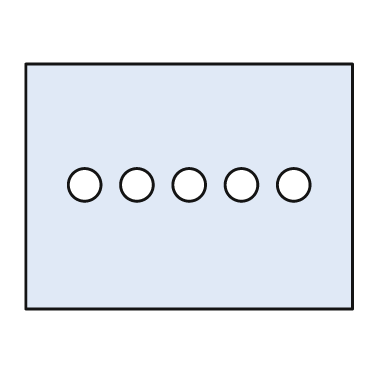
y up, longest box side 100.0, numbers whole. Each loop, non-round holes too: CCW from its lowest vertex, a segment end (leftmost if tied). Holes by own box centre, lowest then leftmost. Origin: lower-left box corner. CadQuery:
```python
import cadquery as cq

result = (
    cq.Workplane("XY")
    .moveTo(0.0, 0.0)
    .lineTo(100.0, 0.0)
    .lineTo(100.0, 75.0)
    .lineTo(0.0, 75.0)
    .close()
    .moveTo(18.0, 38.0)
    .circle(5.0)
    .moveTo(34.0, 38.0)
    .circle(5.0)
    .moveTo(50.0, 38.0)
    .circle(5.0)
    .moveTo(66.0, 38.0)
    .circle(5.0)
    .moveTo(82.0, 38.0)
    .circle(5.0)
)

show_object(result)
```